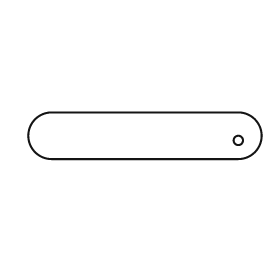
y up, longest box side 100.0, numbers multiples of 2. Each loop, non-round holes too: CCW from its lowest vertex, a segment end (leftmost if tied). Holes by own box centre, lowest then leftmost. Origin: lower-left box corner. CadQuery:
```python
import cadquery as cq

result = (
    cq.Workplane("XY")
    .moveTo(10.0, 0.0)
    .lineTo(90.0, 0.0)
    .threePointArc((100.0, 10.0), (90.0, 20.0))
    .lineTo(10.0, 20.0)
    .threePointArc((0.0, 10.0), (10.0, 0.0))
    .close()
    .moveTo(90.0, 8.0)
    .circle(2.0)
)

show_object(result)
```